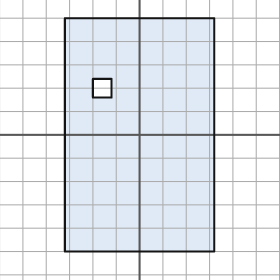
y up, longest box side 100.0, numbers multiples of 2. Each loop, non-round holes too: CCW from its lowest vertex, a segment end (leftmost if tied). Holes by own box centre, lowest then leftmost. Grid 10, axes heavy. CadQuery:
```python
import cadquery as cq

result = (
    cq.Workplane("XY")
    .moveTo(-32.0, -50.0)
    .lineTo(32.0, -50.0)
    .lineTo(32.0, 50.0)
    .lineTo(-32.0, 50.0)
    .close()
    .moveTo(-20.0, 16.0)
    .lineTo(-12.0, 16.0)
    .lineTo(-12.0, 24.0)
    .lineTo(-20.0, 24.0)
    .close()
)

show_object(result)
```